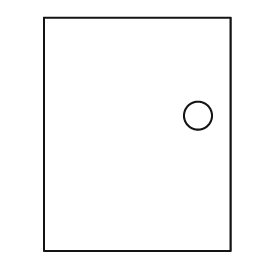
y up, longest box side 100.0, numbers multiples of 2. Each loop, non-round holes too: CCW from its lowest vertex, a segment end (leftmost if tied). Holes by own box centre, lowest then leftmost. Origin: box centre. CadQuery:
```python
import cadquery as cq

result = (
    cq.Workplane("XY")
    .moveTo(-40.0, -50.0)
    .lineTo(40.0, -50.0)
    .lineTo(40.0, 50.0)
    .lineTo(-40.0, 50.0)
    .close()
    .moveTo(26.0, 8.0)
    .circle(6.0)
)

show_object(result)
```